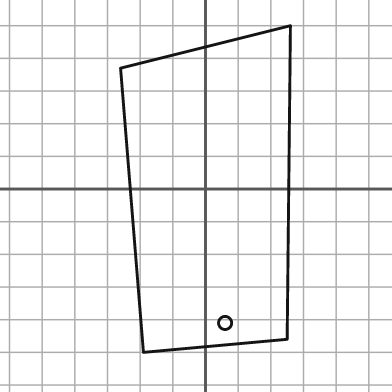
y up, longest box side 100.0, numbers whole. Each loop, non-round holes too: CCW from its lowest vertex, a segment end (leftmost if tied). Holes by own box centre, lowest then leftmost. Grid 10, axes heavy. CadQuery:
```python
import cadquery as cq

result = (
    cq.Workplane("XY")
    .moveTo(-19.0, -50.0)
    .lineTo(25.0, -46.0)
    .lineTo(26.0, 50.0)
    .lineTo(-26.0, 37.0)
    .close()
    .moveTo(6.0, -41.0)
    .circle(2.0)
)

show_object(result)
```